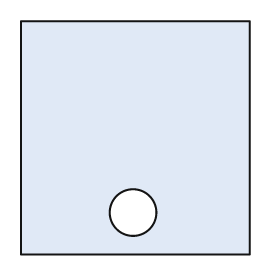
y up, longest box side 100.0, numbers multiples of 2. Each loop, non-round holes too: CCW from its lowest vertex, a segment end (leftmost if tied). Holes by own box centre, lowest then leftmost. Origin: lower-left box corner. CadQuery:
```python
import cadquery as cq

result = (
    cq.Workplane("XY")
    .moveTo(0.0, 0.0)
    .lineTo(98.0, 0.0)
    .lineTo(98.0, 100.0)
    .lineTo(0.0, 100.0)
    .close()
    .moveTo(48.0, 18.0)
    .circle(10.0)
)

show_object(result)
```